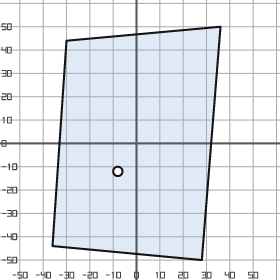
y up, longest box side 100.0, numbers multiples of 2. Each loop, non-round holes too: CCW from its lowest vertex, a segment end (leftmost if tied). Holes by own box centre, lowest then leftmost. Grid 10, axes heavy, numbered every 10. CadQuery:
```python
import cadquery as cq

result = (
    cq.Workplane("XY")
    .moveTo(28.0, -50.0)
    .lineTo(36.0, 50.0)
    .lineTo(-30.0, 44.0)
    .lineTo(-36.0, -44.0)
    .close()
    .moveTo(-8.0, -12.0)
    .circle(2.0)
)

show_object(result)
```